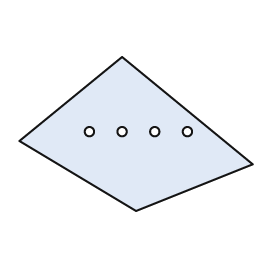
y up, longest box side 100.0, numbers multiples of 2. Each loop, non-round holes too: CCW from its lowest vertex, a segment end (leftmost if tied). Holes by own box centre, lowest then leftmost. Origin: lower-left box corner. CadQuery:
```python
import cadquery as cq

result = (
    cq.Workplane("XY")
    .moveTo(50.0, 0.0)
    .lineTo(100.0, 20.0)
    .lineTo(44.0, 66.0)
    .lineTo(0.0, 30.0)
    .close()
    .moveTo(30.0, 34.0)
    .circle(2.0)
    .moveTo(44.0, 34.0)
    .circle(2.0)
    .moveTo(58.0, 34.0)
    .circle(2.0)
    .moveTo(72.0, 34.0)
    .circle(2.0)
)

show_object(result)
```